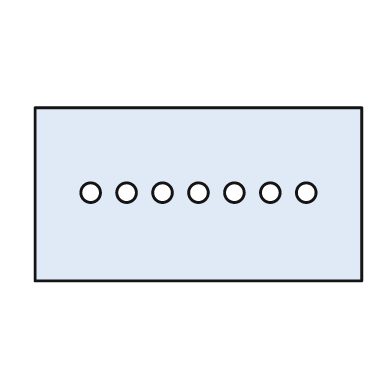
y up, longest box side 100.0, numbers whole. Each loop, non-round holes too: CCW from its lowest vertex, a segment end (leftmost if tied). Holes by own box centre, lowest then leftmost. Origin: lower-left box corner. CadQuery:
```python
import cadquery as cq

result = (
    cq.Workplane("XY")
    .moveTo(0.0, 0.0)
    .lineTo(100.0, 0.0)
    .lineTo(100.0, 53.0)
    .lineTo(0.0, 53.0)
    .close()
    .moveTo(17.0, 27.0)
    .circle(3.0)
    .moveTo(28.0, 27.0)
    .circle(3.0)
    .moveTo(39.0, 27.0)
    .circle(3.0)
    .moveTo(50.0, 27.0)
    .circle(3.0)
    .moveTo(61.0, 27.0)
    .circle(3.0)
    .moveTo(72.0, 27.0)
    .circle(3.0)
    .moveTo(83.0, 27.0)
    .circle(3.0)
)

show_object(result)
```